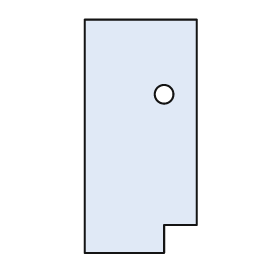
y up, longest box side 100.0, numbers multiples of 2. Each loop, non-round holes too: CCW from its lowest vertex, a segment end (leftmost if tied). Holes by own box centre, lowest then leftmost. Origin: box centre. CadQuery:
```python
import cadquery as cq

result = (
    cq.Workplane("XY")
    .moveTo(-24.0, -50.0)
    .lineTo(10.0, -50.0)
    .lineTo(10.0, -38.0)
    .lineTo(24.0, -38.0)
    .lineTo(24.0, 50.0)
    .lineTo(-24.0, 50.0)
    .close()
    .moveTo(10.0, 18.0)
    .circle(4.0)
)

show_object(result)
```